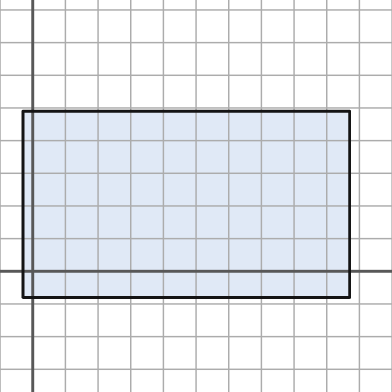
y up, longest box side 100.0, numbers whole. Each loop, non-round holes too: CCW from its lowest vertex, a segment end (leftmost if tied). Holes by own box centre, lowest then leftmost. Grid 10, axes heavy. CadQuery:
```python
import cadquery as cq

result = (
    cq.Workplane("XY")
    .moveTo(-3.0, -8.0)
    .lineTo(97.0, -8.0)
    .lineTo(97.0, 49.0)
    .lineTo(-3.0, 49.0)
    .close()
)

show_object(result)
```